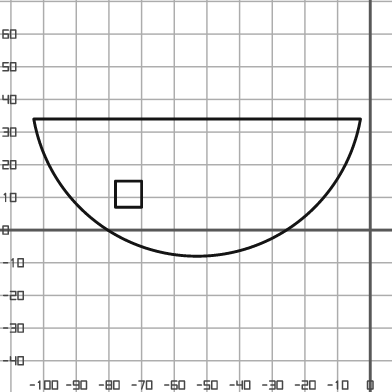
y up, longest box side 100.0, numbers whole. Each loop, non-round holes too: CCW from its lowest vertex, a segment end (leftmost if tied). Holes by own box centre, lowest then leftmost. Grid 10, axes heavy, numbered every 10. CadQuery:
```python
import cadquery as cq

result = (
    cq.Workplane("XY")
    .moveTo(-103.0, 34.0)
    .threePointArc((-53.0, -8.0), (-3.0, 34.0))
    .close()
    .moveTo(-78.0, 7.0)
    .lineTo(-70.0, 7.0)
    .lineTo(-70.0, 15.0)
    .lineTo(-78.0, 15.0)
    .close()
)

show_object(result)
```